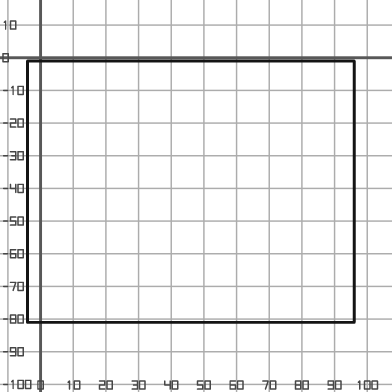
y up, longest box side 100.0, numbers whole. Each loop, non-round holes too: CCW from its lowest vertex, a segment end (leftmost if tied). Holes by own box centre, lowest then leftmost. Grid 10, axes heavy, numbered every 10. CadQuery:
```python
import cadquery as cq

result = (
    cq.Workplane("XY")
    .moveTo(-4.0, -81.0)
    .lineTo(96.0, -81.0)
    .lineTo(96.0, -1.0)
    .lineTo(-4.0, -1.0)
    .close()
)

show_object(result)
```